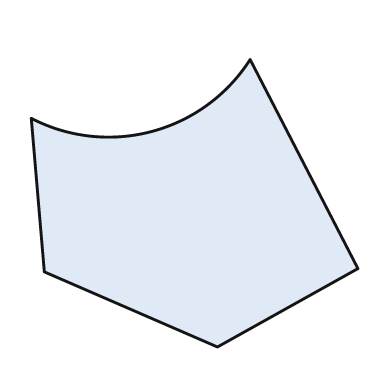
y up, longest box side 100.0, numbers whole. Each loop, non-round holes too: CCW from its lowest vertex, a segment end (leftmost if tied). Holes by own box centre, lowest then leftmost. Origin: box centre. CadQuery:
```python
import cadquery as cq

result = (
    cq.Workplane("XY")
    .moveTo(7.0, -44.0)
    .lineTo(50.0, -20.0)
    .lineTo(17.0, 44.0)
    .threePointArc((-13.0, 22.0), (-50.0, 26.0))
    .lineTo(-46.0, -21.0)
    .close()
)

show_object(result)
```